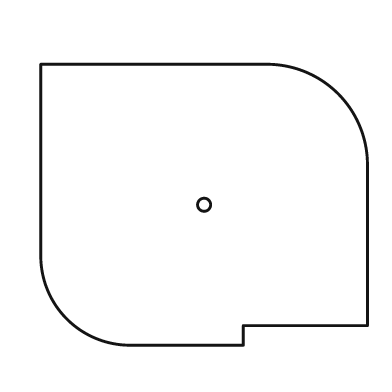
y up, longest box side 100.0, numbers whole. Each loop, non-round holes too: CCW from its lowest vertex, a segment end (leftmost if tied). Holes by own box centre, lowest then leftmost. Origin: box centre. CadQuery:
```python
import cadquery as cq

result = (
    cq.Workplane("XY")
    .moveTo(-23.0, -43.0)
    .lineTo(12.0, -43.0)
    .lineTo(12.0, -37.0)
    .lineTo(50.0, -37.0)
    .lineTo(50.0, 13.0)
    .threePointArc((41.0, 34.0), (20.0, 43.0))
    .lineTo(-50.0, 43.0)
    .lineTo(-50.0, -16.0)
    .threePointArc((-42.0, -35.0), (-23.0, -43.0))
    .close()
    .moveTo(0.0, 0.0)
    .circle(2.0)
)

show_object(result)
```